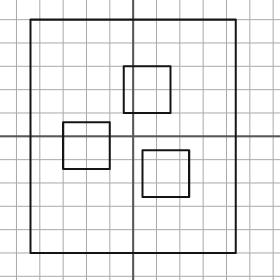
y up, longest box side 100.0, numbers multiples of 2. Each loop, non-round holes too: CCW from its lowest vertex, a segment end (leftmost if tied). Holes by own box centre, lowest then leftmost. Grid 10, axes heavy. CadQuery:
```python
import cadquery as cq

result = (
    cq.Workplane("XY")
    .moveTo(-44.0, -50.0)
    .lineTo(44.0, -50.0)
    .lineTo(44.0, 50.0)
    .lineTo(-44.0, 50.0)
    .close()
    .moveTo(4.0, -26.0)
    .lineTo(24.0, -26.0)
    .lineTo(24.0, -6.0)
    .lineTo(4.0, -6.0)
    .close()
    .moveTo(-30.0, -14.0)
    .lineTo(-10.0, -14.0)
    .lineTo(-10.0, 6.0)
    .lineTo(-30.0, 6.0)
    .close()
    .moveTo(-4.0, 10.0)
    .lineTo(16.0, 10.0)
    .lineTo(16.0, 30.0)
    .lineTo(-4.0, 30.0)
    .close()
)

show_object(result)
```